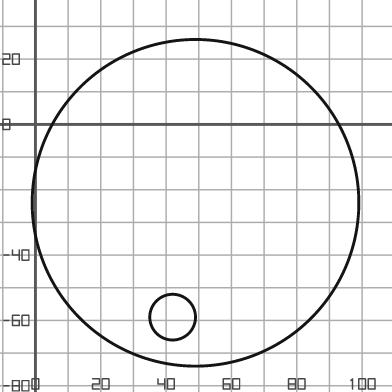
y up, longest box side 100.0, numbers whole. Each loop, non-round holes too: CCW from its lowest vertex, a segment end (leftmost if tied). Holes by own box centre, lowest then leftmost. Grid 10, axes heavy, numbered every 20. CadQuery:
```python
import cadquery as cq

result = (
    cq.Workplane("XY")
    .moveTo(49.0, -24.0)
    .circle(50.0)
    .moveTo(42.0, -59.0)
    .circle(7.0)
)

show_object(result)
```